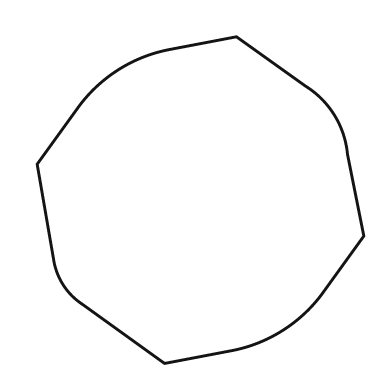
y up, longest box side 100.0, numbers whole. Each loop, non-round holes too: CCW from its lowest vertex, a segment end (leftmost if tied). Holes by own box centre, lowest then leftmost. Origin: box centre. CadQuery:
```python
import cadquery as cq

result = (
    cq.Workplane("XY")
    .moveTo(-11.0, -50.0)
    .lineTo(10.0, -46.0)
    .threePointArc((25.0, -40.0), (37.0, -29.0))
    .lineTo(50.0, -11.0)
    .lineTo(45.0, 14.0)
    .threePointArc((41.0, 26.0), (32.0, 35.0))
    .lineTo(11.0, 50.0)
    .lineTo(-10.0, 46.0)
    .threePointArc((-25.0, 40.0), (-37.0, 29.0))
    .lineTo(-50.0, 11.0)
    .lineTo(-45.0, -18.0)
    .threePointArc((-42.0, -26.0), (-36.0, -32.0))
    .close()
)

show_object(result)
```